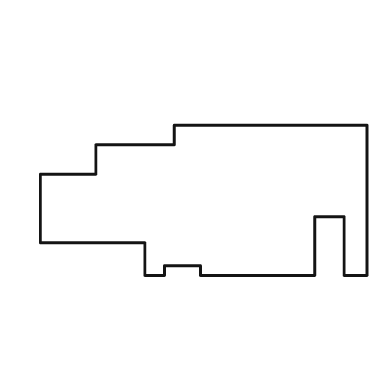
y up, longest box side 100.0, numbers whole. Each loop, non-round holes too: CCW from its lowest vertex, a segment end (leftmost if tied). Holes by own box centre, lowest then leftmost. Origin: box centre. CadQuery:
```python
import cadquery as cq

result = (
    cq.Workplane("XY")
    .moveTo(-18.0, -23.0)
    .lineTo(-12.0, -23.0)
    .lineTo(-12.0, -20.0)
    .lineTo(-1.0, -20.0)
    .lineTo(-1.0, -23.0)
    .lineTo(34.0, -23.0)
    .lineTo(34.0, -5.0)
    .lineTo(43.0, -5.0)
    .lineTo(43.0, -23.0)
    .lineTo(50.0, -23.0)
    .lineTo(50.0, 23.0)
    .lineTo(-9.0, 23.0)
    .lineTo(-9.0, 17.0)
    .lineTo(-33.0, 17.0)
    .lineTo(-33.0, 8.0)
    .lineTo(-50.0, 8.0)
    .lineTo(-50.0, -13.0)
    .lineTo(-18.0, -13.0)
    .close()
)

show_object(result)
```